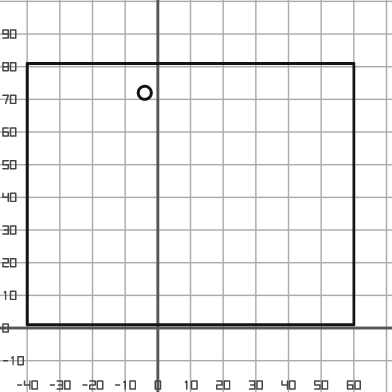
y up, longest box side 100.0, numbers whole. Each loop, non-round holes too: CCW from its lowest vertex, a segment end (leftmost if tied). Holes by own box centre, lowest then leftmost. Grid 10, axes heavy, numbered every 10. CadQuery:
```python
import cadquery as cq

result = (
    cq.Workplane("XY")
    .moveTo(-40.0, 1.0)
    .lineTo(60.0, 1.0)
    .lineTo(60.0, 81.0)
    .lineTo(-40.0, 81.0)
    .close()
    .moveTo(-4.0, 72.0)
    .circle(2.0)
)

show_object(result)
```